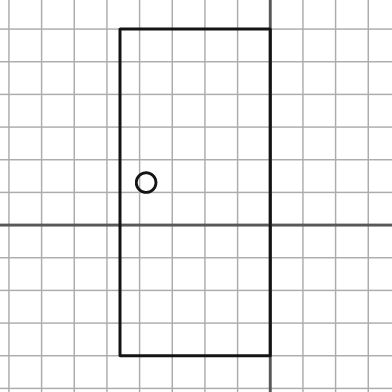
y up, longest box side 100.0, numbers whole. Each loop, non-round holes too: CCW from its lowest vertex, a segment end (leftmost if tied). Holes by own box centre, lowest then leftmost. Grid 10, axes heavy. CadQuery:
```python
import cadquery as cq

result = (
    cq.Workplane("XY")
    .moveTo(-46.0, -40.0)
    .lineTo(0.0, -40.0)
    .lineTo(0.0, 60.0)
    .lineTo(-46.0, 60.0)
    .close()
    .moveTo(-38.0, 13.0)
    .circle(3.0)
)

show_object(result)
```